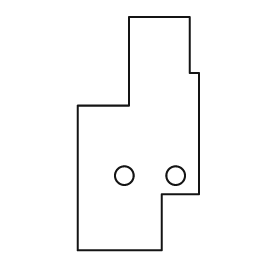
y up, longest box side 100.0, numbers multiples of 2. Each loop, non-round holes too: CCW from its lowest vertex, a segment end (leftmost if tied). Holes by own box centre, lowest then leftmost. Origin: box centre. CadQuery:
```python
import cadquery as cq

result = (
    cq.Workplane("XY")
    .moveTo(-26.0, -50.0)
    .lineTo(10.0, -50.0)
    .lineTo(10.0, -26.0)
    .lineTo(26.0, -26.0)
    .lineTo(26.0, 26.0)
    .lineTo(22.0, 26.0)
    .lineTo(22.0, 50.0)
    .lineTo(-4.0, 50.0)
    .lineTo(-4.0, 12.0)
    .lineTo(-26.0, 12.0)
    .close()
    .moveTo(-6.0, -18.0)
    .circle(4.0)
    .moveTo(16.0, -18.0)
    .circle(4.0)
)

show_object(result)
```